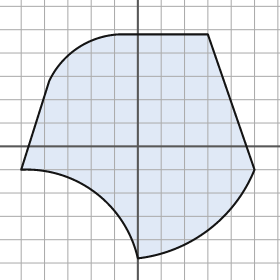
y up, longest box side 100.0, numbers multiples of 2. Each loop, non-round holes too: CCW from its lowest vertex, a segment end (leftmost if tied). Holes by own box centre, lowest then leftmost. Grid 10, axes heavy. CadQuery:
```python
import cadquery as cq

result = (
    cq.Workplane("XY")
    .moveTo(0.0, -48.0)
    .threePointArc((30.0, -36.0), (50.0, -10.0))
    .lineTo(30.0, 48.0)
    .lineTo(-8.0, 48.0)
    .threePointArc((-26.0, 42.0), (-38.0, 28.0))
    .lineTo(-50.0, -10.0)
    .threePointArc((-18.0, -20.0), (0.0, -48.0))
    .close()
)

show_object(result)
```